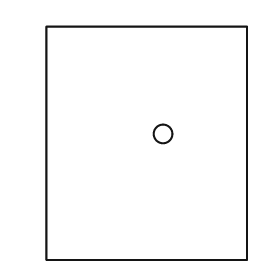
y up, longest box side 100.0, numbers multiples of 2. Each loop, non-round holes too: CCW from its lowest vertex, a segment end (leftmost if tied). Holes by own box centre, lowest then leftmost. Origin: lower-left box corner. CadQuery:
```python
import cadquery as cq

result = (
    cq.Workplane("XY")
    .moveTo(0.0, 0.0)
    .lineTo(86.0, 0.0)
    .lineTo(86.0, 100.0)
    .lineTo(0.0, 100.0)
    .close()
    .moveTo(50.0, 54.0)
    .circle(4.0)
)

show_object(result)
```